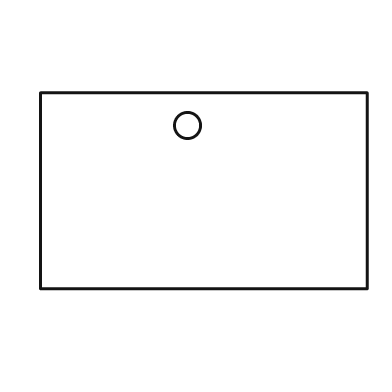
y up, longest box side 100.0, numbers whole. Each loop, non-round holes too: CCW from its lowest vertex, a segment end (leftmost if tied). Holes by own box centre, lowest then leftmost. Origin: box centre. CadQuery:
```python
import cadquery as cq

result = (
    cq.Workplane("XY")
    .moveTo(-50.0, -30.0)
    .lineTo(50.0, -30.0)
    .lineTo(50.0, 30.0)
    .lineTo(-50.0, 30.0)
    .close()
    .moveTo(-5.0, 20.0)
    .circle(4.0)
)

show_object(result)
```